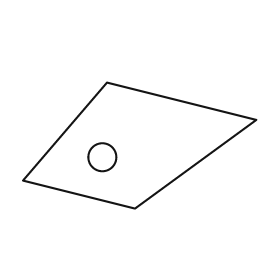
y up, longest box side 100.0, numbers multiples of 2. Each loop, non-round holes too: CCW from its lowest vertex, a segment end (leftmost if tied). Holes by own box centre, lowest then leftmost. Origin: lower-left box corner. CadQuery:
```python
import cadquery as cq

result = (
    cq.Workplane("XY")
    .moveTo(48.0, 0.0)
    .lineTo(100.0, 38.0)
    .lineTo(36.0, 54.0)
    .lineTo(0.0, 12.0)
    .close()
    .moveTo(34.0, 22.0)
    .circle(6.0)
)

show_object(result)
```